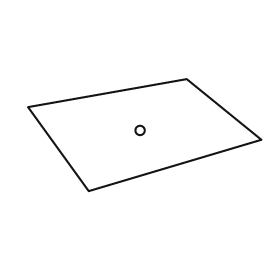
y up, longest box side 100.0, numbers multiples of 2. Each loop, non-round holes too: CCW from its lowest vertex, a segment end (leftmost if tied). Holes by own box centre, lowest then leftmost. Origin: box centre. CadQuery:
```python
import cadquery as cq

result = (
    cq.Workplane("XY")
    .moveTo(-24.0, -24.0)
    .lineTo(50.0, -2.0)
    .lineTo(18.0, 24.0)
    .lineTo(-50.0, 12.0)
    .close()
    .moveTo(-2.0, 2.0)
    .circle(2.0)
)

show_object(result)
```